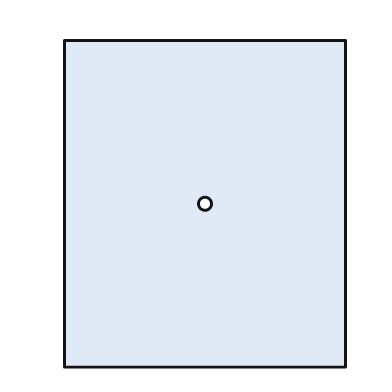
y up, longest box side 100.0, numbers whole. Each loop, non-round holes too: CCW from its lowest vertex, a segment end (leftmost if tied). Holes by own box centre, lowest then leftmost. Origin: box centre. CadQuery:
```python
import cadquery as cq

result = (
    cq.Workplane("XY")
    .moveTo(-43.0, -50.0)
    .lineTo(43.0, -50.0)
    .lineTo(43.0, 50.0)
    .lineTo(-43.0, 50.0)
    .close()
    .moveTo(0.0, 0.0)
    .circle(2.0)
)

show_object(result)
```